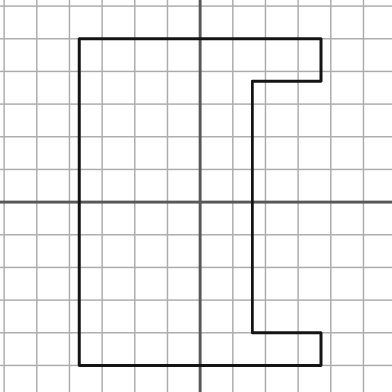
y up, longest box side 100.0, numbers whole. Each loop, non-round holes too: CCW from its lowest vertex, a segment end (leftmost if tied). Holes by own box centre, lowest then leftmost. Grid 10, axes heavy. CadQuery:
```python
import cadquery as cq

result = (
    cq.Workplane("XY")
    .moveTo(-37.0, -50.0)
    .lineTo(37.0, -50.0)
    .lineTo(37.0, -40.0)
    .lineTo(16.0, -40.0)
    .lineTo(16.0, 37.0)
    .lineTo(37.0, 37.0)
    .lineTo(37.0, 50.0)
    .lineTo(-37.0, 50.0)
    .close()
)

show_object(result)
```